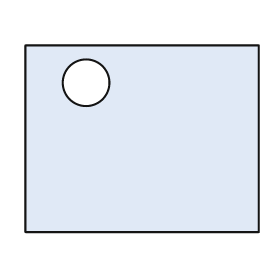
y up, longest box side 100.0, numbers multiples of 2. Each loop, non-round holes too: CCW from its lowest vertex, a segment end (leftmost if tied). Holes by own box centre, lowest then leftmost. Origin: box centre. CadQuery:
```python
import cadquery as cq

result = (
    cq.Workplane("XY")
    .moveTo(-50.0, -40.0)
    .lineTo(50.0, -40.0)
    .lineTo(50.0, 40.0)
    .lineTo(-50.0, 40.0)
    .close()
    .moveTo(-24.0, 24.0)
    .circle(10.0)
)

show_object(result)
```